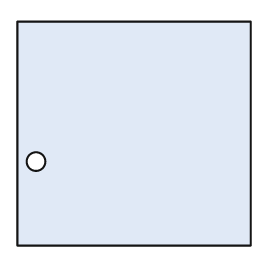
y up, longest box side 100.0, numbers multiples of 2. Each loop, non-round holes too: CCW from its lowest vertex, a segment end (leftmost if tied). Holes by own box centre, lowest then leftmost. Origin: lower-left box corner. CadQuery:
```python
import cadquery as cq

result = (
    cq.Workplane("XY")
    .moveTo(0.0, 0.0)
    .lineTo(100.0, 0.0)
    .lineTo(100.0, 96.0)
    .lineTo(0.0, 96.0)
    .close()
    .moveTo(8.0, 36.0)
    .circle(4.0)
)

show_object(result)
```